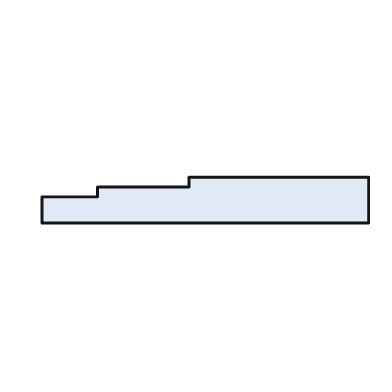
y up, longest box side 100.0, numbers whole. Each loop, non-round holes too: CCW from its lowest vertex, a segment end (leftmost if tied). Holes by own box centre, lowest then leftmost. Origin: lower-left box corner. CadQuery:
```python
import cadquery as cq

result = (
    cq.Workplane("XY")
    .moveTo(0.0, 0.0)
    .lineTo(100.0, 0.0)
    .lineTo(100.0, 14.0)
    .lineTo(45.0, 14.0)
    .lineTo(45.0, 11.0)
    .lineTo(17.0, 11.0)
    .lineTo(17.0, 8.0)
    .lineTo(0.0, 8.0)
    .close()
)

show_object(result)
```